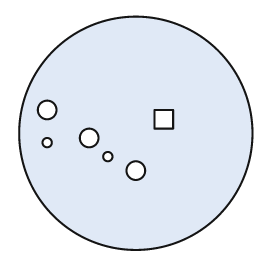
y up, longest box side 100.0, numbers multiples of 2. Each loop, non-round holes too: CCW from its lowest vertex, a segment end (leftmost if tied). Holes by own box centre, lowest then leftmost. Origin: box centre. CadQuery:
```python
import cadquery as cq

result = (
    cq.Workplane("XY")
    .moveTo(0.0, 0.0)
    .circle(50.0)
    .moveTo(0.0, -16.0)
    .circle(4.0)
    .moveTo(-12.0, -10.0)
    .circle(2.0)
    .moveTo(-38.0, -4.0)
    .circle(2.0)
    .moveTo(-20.0, -2.0)
    .circle(4.0)
    .moveTo(8.0, 2.0)
    .lineTo(16.0, 2.0)
    .lineTo(16.0, 10.0)
    .lineTo(8.0, 10.0)
    .close()
    .moveTo(-38.0, 10.0)
    .circle(4.0)
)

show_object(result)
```